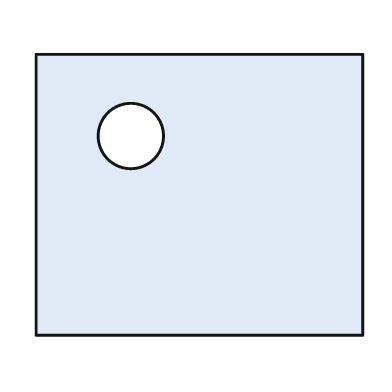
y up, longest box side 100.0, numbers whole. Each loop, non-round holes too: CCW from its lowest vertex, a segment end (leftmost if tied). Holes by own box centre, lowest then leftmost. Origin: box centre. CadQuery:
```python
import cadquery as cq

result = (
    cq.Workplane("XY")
    .moveTo(-50.0, -43.0)
    .lineTo(50.0, -43.0)
    .lineTo(50.0, 43.0)
    .lineTo(-50.0, 43.0)
    .close()
    .moveTo(-21.0, 18.0)
    .circle(10.0)
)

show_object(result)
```